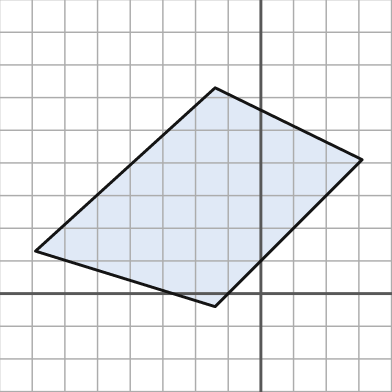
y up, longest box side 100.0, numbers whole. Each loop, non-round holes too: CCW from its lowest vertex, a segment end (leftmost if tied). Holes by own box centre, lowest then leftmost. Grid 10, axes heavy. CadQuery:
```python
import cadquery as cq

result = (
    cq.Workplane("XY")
    .moveTo(-14.0, -4.0)
    .lineTo(31.0, 41.0)
    .lineTo(-14.0, 63.0)
    .lineTo(-69.0, 13.0)
    .close()
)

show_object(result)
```